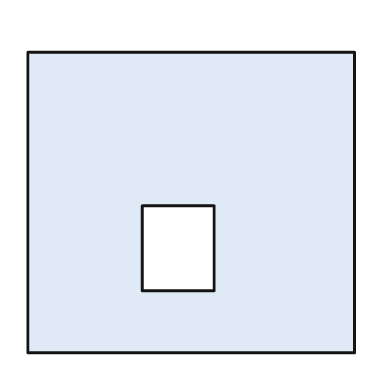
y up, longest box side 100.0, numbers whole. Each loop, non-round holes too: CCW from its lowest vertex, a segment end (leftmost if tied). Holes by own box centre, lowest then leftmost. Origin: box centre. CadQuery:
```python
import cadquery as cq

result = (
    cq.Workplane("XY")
    .moveTo(-50.0, -46.0)
    .lineTo(50.0, -46.0)
    .lineTo(50.0, 46.0)
    .lineTo(-50.0, 46.0)
    .close()
    .moveTo(-15.0, -27.0)
    .lineTo(7.0, -27.0)
    .lineTo(7.0, -1.0)
    .lineTo(-15.0, -1.0)
    .close()
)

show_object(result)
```